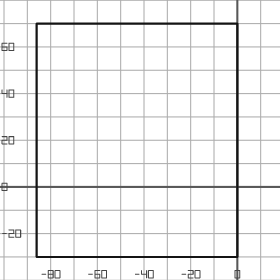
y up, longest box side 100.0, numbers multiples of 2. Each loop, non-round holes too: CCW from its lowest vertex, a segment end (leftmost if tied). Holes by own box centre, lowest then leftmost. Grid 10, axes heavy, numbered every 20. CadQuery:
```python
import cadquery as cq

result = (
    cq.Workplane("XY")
    .moveTo(-86.0, -30.0)
    .lineTo(0.0, -30.0)
    .lineTo(0.0, 70.0)
    .lineTo(-86.0, 70.0)
    .close()
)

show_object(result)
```